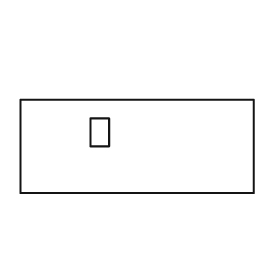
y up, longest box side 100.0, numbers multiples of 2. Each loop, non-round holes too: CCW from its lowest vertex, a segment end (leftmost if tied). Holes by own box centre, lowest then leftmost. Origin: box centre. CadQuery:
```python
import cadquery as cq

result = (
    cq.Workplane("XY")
    .moveTo(-50.0, -20.0)
    .lineTo(50.0, -20.0)
    .lineTo(50.0, 20.0)
    .lineTo(-50.0, 20.0)
    .close()
    .moveTo(-20.0, 0.0)
    .lineTo(-12.0, 0.0)
    .lineTo(-12.0, 12.0)
    .lineTo(-20.0, 12.0)
    .close()
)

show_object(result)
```